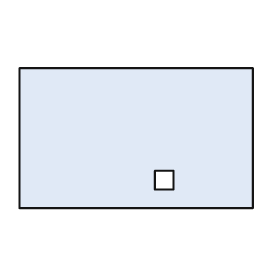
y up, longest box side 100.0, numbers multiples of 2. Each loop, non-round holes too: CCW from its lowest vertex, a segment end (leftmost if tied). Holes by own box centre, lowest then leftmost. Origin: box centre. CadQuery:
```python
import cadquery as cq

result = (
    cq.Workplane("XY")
    .moveTo(-50.0, -30.0)
    .lineTo(50.0, -30.0)
    .lineTo(50.0, 30.0)
    .lineTo(-50.0, 30.0)
    .close()
    .moveTo(8.0, -22.0)
    .lineTo(16.0, -22.0)
    .lineTo(16.0, -14.0)
    .lineTo(8.0, -14.0)
    .close()
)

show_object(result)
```